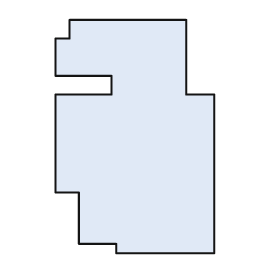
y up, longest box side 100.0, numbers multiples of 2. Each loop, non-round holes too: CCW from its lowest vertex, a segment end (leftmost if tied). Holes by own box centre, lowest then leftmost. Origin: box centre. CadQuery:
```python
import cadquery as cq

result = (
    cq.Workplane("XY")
    .moveTo(-8.0, -50.0)
    .lineTo(34.0, -50.0)
    .lineTo(34.0, 18.0)
    .lineTo(22.0, 18.0)
    .lineTo(22.0, 50.0)
    .lineTo(-28.0, 50.0)
    .lineTo(-28.0, 42.0)
    .lineTo(-34.0, 42.0)
    .lineTo(-34.0, 26.0)
    .lineTo(-10.0, 26.0)
    .lineTo(-10.0, 18.0)
    .lineTo(-34.0, 18.0)
    .lineTo(-34.0, -24.0)
    .lineTo(-24.0, -24.0)
    .lineTo(-24.0, -46.0)
    .lineTo(-8.0, -46.0)
    .close()
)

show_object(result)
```